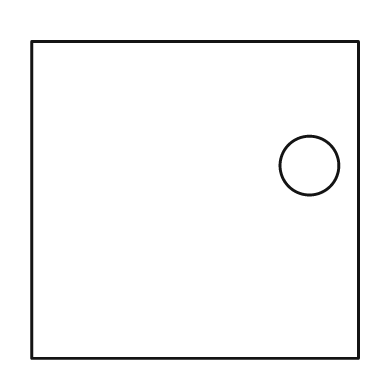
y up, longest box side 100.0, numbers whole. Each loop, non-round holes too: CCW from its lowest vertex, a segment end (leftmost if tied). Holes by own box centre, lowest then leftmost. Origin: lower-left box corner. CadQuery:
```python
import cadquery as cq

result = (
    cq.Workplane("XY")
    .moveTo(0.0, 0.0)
    .lineTo(100.0, 0.0)
    .lineTo(100.0, 97.0)
    .lineTo(0.0, 97.0)
    .close()
    .moveTo(85.0, 59.0)
    .circle(9.0)
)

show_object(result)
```